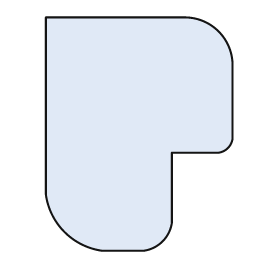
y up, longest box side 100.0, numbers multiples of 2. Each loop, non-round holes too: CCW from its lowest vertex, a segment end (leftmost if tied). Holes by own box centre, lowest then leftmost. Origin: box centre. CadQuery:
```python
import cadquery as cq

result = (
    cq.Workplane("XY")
    .moveTo(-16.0, -50.0)
    .lineTo(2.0, -50.0)
    .threePointArc((10.0, -46.0), (14.0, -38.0))
    .lineTo(14.0, -8.0)
    .lineTo(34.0, -8.0)
    .threePointArc((38.0, -6.0), (40.0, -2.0))
    .lineTo(40.0, 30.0)
    .threePointArc((34.0, 44.0), (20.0, 50.0))
    .lineTo(-40.0, 50.0)
    .lineTo(-40.0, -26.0)
    .threePointArc((-32.0, -42.0), (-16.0, -50.0))
    .close()
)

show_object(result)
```